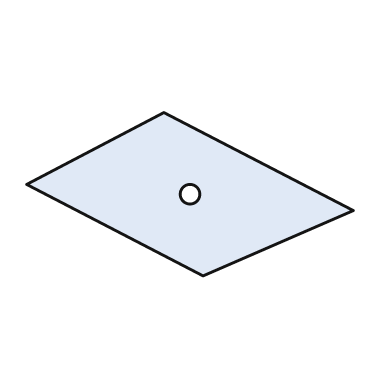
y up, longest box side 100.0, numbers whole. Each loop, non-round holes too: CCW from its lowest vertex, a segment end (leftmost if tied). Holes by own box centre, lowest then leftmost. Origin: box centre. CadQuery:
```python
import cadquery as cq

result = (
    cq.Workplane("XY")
    .moveTo(4.0, -25.0)
    .lineTo(50.0, -5.0)
    .lineTo(-8.0, 25.0)
    .lineTo(-50.0, 3.0)
    .close()
    .moveTo(0.0, 0.0)
    .circle(3.0)
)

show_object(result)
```